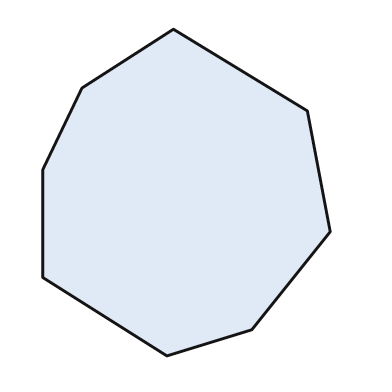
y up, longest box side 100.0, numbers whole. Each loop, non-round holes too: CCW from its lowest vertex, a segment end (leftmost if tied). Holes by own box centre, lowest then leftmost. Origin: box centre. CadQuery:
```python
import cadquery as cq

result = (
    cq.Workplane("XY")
    .moveTo(-6.0, -50.0)
    .lineTo(20.0, -42.0)
    .lineTo(44.0, -12.0)
    .lineTo(37.0, 25.0)
    .lineTo(-4.0, 50.0)
    .lineTo(-32.0, 32.0)
    .lineTo(-44.0, 7.0)
    .lineTo(-44.0, -26.0)
    .close()
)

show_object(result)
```